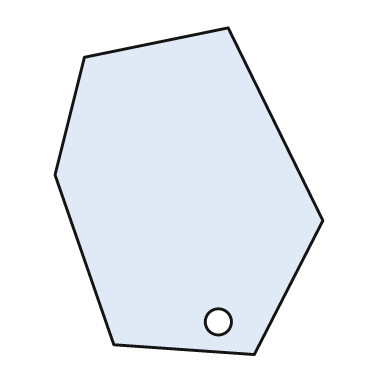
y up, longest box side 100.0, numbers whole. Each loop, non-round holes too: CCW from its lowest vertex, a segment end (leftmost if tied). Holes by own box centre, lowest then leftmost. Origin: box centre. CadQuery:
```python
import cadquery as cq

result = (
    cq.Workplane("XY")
    .moveTo(20.0, -50.0)
    .lineTo(41.0, -9.0)
    .lineTo(12.0, 50.0)
    .lineTo(-32.0, 41.0)
    .lineTo(-41.0, 5.0)
    .lineTo(-23.0, -47.0)
    .close()
    .moveTo(9.0, -40.0)
    .circle(4.0)
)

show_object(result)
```